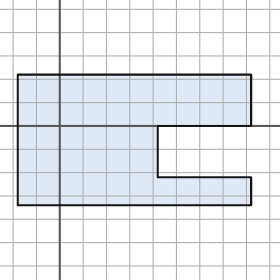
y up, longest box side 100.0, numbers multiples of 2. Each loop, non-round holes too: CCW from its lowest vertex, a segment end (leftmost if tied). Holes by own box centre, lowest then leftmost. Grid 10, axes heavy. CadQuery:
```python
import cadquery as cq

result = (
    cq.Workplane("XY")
    .moveTo(-18.0, -34.0)
    .lineTo(82.0, -34.0)
    .lineTo(82.0, -22.0)
    .lineTo(42.0, -22.0)
    .lineTo(42.0, 0.0)
    .lineTo(82.0, 0.0)
    .lineTo(82.0, 22.0)
    .lineTo(-18.0, 22.0)
    .close()
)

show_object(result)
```